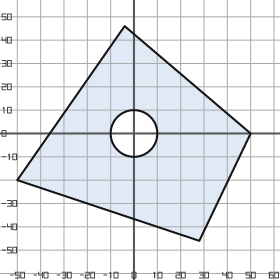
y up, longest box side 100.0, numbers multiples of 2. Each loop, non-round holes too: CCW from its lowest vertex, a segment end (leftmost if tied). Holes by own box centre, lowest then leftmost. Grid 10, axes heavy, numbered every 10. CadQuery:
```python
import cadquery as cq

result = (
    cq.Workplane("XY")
    .moveTo(28.0, -46.0)
    .lineTo(50.0, 0.0)
    .lineTo(-4.0, 46.0)
    .lineTo(-50.0, -20.0)
    .close()
    .moveTo(0.0, 0.0)
    .circle(10.0)
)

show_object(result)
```